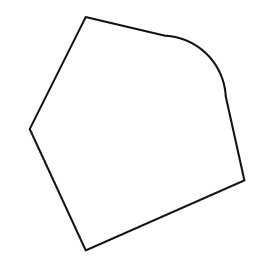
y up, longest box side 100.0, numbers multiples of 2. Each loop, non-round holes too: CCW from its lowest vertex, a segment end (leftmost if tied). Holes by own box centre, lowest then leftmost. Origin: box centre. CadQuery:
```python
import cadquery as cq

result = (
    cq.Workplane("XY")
    .moveTo(-22.0, -50.0)
    .lineTo(46.0, -20.0)
    .lineTo(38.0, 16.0)
    .threePointArc((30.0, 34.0), (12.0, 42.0))
    .lineTo(-22.0, 50.0)
    .lineTo(-46.0, 2.0)
    .close()
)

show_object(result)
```